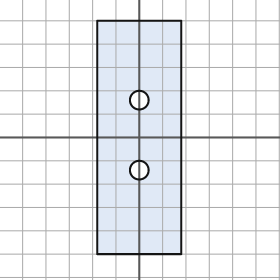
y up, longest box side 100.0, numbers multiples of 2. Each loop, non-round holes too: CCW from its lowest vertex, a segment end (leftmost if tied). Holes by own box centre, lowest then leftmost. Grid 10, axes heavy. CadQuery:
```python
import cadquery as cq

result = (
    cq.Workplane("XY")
    .moveTo(-18.0, -50.0)
    .lineTo(18.0, -50.0)
    .lineTo(18.0, 50.0)
    .lineTo(-18.0, 50.0)
    .close()
    .moveTo(0.0, -14.0)
    .circle(4.0)
    .moveTo(0.0, 16.0)
    .circle(4.0)
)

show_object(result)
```